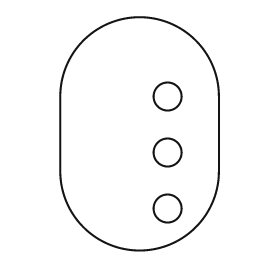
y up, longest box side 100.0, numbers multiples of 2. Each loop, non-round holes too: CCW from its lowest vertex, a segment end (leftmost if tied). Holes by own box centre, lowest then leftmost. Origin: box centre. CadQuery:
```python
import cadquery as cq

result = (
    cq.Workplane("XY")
    .moveTo(-34.0, -16.0)
    .threePointArc((0.0, -50.0), (34.0, -16.0))
    .lineTo(34.0, 16.0)
    .threePointArc((0.0, 50.0), (-34.0, 16.0))
    .close()
    .moveTo(12.0, -32.0)
    .circle(6.0)
    .moveTo(12.0, -8.0)
    .circle(6.0)
    .moveTo(12.0, 16.0)
    .circle(6.0)
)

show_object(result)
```